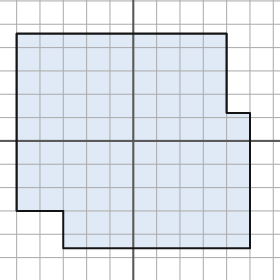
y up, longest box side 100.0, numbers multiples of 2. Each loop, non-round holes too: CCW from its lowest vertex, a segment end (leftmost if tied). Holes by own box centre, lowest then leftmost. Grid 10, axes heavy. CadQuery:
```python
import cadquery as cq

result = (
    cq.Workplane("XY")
    .moveTo(-30.0, -46.0)
    .lineTo(50.0, -46.0)
    .lineTo(50.0, 12.0)
    .lineTo(40.0, 12.0)
    .lineTo(40.0, 46.0)
    .lineTo(-50.0, 46.0)
    .lineTo(-50.0, -30.0)
    .lineTo(-30.0, -30.0)
    .close()
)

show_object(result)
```